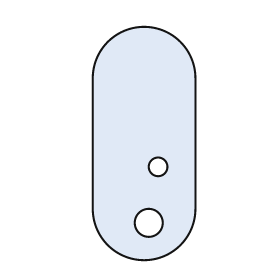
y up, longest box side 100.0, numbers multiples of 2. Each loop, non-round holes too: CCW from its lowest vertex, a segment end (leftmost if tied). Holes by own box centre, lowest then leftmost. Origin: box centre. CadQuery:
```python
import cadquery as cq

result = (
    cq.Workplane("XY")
    .moveTo(-22.0, -28.0)
    .threePointArc((0.0, -50.0), (22.0, -28.0))
    .lineTo(22.0, 28.0)
    .threePointArc((0.0, 50.0), (-22.0, 28.0))
    .close()
    .moveTo(2.0, -34.0)
    .circle(6.0)
    .moveTo(6.0, -10.0)
    .circle(4.0)
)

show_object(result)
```